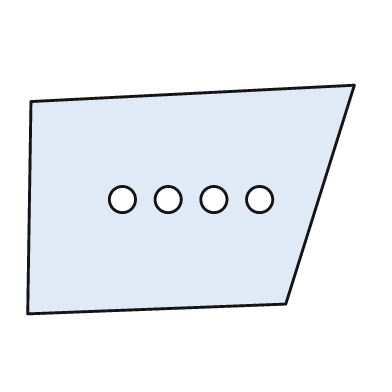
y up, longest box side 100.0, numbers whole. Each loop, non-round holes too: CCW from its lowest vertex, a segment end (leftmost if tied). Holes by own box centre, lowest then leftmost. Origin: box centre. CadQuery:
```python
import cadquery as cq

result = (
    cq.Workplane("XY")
    .moveTo(-50.0, -35.0)
    .lineTo(29.0, -32.0)
    .lineTo(50.0, 35.0)
    .lineTo(-49.0, 30.0)
    .close()
    .moveTo(-21.0, 0.0)
    .circle(4.0)
    .moveTo(-7.0, 0.0)
    .circle(4.0)
    .moveTo(7.0, 0.0)
    .circle(4.0)
    .moveTo(21.0, 0.0)
    .circle(4.0)
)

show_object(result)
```